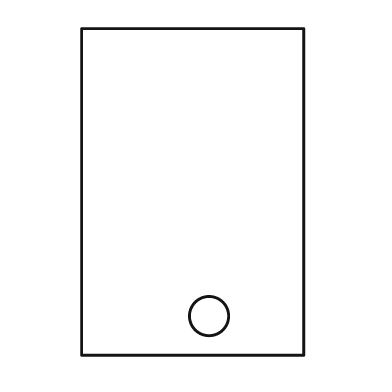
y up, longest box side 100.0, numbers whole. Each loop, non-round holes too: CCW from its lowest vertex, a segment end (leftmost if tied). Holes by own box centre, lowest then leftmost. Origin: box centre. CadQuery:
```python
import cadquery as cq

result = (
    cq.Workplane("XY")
    .moveTo(-34.0, -50.0)
    .lineTo(34.0, -50.0)
    .lineTo(34.0, 50.0)
    .lineTo(-34.0, 50.0)
    .close()
    .moveTo(5.0, -38.0)
    .circle(6.0)
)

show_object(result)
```